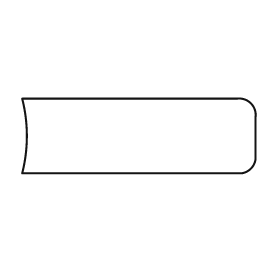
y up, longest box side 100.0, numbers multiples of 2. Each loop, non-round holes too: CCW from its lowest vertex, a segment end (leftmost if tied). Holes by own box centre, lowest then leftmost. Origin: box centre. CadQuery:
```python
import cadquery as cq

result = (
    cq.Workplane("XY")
    .moveTo(-50.0, -16.0)
    .lineTo(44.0, -16.0)
    .threePointArc((48.0, -14.0), (50.0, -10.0))
    .lineTo(50.0, 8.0)
    .threePointArc((48.0, 14.0), (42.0, 16.0))
    .lineTo(-50.0, 16.0)
    .threePointArc((-48.0, 0.0), (-50.0, -16.0))
    .close()
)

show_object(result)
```